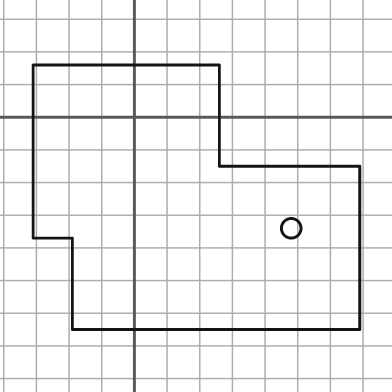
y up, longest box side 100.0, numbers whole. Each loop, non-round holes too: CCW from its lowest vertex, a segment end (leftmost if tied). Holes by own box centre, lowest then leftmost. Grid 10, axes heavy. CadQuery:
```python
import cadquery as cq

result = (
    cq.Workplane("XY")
    .moveTo(-19.0, -65.0)
    .lineTo(69.0, -65.0)
    .lineTo(69.0, -15.0)
    .lineTo(26.0, -15.0)
    .lineTo(26.0, 16.0)
    .lineTo(-31.0, 16.0)
    .lineTo(-31.0, -37.0)
    .lineTo(-19.0, -37.0)
    .close()
    .moveTo(48.0, -34.0)
    .circle(3.0)
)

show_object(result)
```